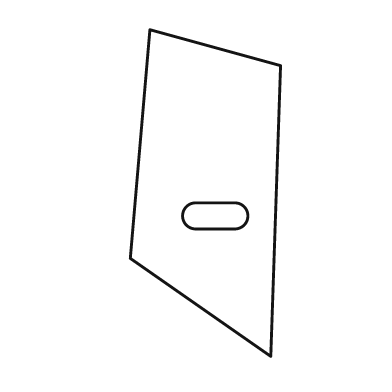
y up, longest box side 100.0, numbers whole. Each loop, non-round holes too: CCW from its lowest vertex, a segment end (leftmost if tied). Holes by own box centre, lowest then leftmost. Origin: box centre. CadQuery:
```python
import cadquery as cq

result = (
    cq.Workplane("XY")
    .moveTo(20.0, -50.0)
    .lineTo(23.0, 39.0)
    .lineTo(-17.0, 50.0)
    .lineTo(-23.0, -20.0)
    .close()
    .moveTo(-3.0, -11.0)
    .lineTo(9.0, -11.0)
    .threePointArc((13.0, -7.0), (9.0, -3.0))
    .lineTo(-3.0, -3.0)
    .threePointArc((-7.0, -7.0), (-3.0, -11.0))
    .close()
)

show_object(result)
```